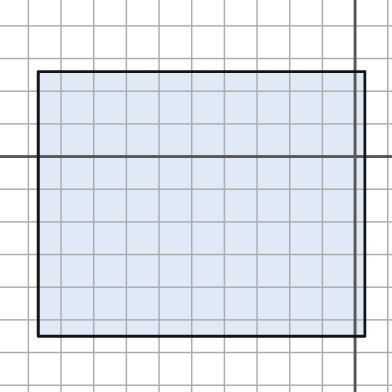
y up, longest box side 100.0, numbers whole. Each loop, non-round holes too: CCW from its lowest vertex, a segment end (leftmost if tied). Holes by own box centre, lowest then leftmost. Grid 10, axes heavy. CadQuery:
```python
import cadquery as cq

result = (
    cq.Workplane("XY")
    .moveTo(-97.0, -55.0)
    .lineTo(3.0, -55.0)
    .lineTo(3.0, 26.0)
    .lineTo(-97.0, 26.0)
    .close()
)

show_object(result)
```